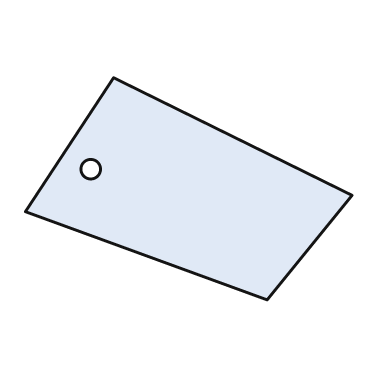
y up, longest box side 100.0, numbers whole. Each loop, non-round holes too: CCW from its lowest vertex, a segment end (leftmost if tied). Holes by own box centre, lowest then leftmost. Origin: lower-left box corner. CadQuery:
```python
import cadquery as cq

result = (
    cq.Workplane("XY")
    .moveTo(74.0, 0.0)
    .lineTo(100.0, 32.0)
    .lineTo(27.0, 68.0)
    .lineTo(0.0, 27.0)
    .close()
    .moveTo(20.0, 40.0)
    .circle(3.0)
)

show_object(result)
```